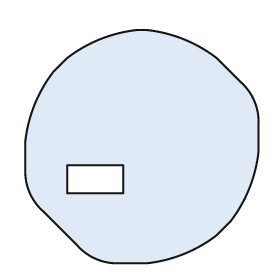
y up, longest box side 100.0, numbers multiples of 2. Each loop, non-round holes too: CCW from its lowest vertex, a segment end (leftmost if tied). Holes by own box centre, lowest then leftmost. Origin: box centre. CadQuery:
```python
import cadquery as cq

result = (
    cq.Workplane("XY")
    .moveTo(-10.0, -50.0)
    .lineTo(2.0, -50.0)
    .threePointArc((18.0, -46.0), (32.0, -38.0))
    .lineTo(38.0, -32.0)
    .threePointArc((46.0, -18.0), (50.0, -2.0))
    .lineTo(50.0, 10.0)
    .threePointArc((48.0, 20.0), (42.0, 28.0))
    .lineTo(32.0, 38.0)
    .threePointArc((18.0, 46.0), (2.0, 50.0))
    .lineTo(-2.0, 50.0)
    .threePointArc((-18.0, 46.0), (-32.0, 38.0))
    .lineTo(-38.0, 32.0)
    .threePointArc((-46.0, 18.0), (-50.0, 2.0))
    .lineTo(-50.0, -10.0)
    .threePointArc((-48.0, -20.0), (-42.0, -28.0))
    .lineTo(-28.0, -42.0)
    .threePointArc((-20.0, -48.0), (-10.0, -50.0))
    .close()
    .moveTo(-32.0, -20.0)
    .lineTo(-8.0, -20.0)
    .lineTo(-8.0, -8.0)
    .lineTo(-32.0, -8.0)
    .close()
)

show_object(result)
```